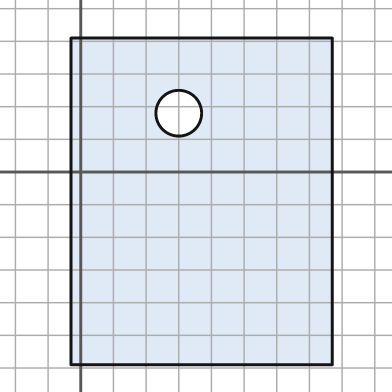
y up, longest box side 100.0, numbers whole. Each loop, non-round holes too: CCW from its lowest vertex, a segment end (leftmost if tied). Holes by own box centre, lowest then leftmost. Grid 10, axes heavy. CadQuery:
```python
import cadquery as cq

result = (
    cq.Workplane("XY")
    .moveTo(-3.0, -59.0)
    .lineTo(77.0, -59.0)
    .lineTo(77.0, 41.0)
    .lineTo(-3.0, 41.0)
    .close()
    .moveTo(30.0, 18.0)
    .circle(7.0)
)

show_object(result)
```